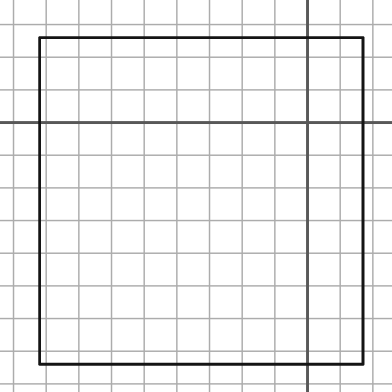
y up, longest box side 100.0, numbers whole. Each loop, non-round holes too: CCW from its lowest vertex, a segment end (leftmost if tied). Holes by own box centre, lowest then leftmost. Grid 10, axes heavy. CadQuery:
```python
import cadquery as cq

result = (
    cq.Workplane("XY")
    .moveTo(-82.0, -74.0)
    .lineTo(17.0, -74.0)
    .lineTo(17.0, 26.0)
    .lineTo(-82.0, 26.0)
    .close()
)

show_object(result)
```